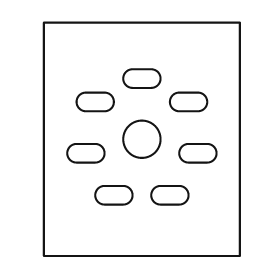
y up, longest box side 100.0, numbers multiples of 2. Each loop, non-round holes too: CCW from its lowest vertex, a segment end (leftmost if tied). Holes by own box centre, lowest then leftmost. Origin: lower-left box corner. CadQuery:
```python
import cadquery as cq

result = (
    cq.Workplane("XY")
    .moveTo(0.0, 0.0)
    .lineTo(84.0, 0.0)
    .lineTo(84.0, 100.0)
    .lineTo(0.0, 100.0)
    .close()
    .moveTo(26.0, 22.0)
    .lineTo(34.0, 22.0)
    .threePointArc((38.0, 26.0), (34.0, 30.0))
    .lineTo(26.0, 30.0)
    .threePointArc((22.0, 26.0), (26.0, 22.0))
    .close()
    .moveTo(50.0, 22.0)
    .lineTo(58.0, 22.0)
    .threePointArc((62.0, 26.0), (58.0, 30.0))
    .lineTo(50.0, 30.0)
    .threePointArc((46.0, 26.0), (50.0, 22.0))
    .close()
    .moveTo(14.0, 40.0)
    .lineTo(22.0, 40.0)
    .threePointArc((26.0, 44.0), (22.0, 48.0))
    .lineTo(14.0, 48.0)
    .threePointArc((10.0, 44.0), (14.0, 40.0))
    .close()
    .moveTo(62.0, 40.0)
    .lineTo(70.0, 40.0)
    .threePointArc((74.0, 44.0), (70.0, 48.0))
    .lineTo(62.0, 48.0)
    .threePointArc((58.0, 44.0), (62.0, 40.0))
    .close()
    .moveTo(42.0, 50.0)
    .circle(8.0)
    .moveTo(18.0, 62.0)
    .lineTo(26.0, 62.0)
    .threePointArc((30.0, 66.0), (26.0, 70.0))
    .lineTo(18.0, 70.0)
    .threePointArc((14.0, 66.0), (18.0, 62.0))
    .close()
    .moveTo(58.0, 62.0)
    .lineTo(66.0, 62.0)
    .threePointArc((70.0, 66.0), (66.0, 70.0))
    .lineTo(58.0, 70.0)
    .threePointArc((54.0, 66.0), (58.0, 62.0))
    .close()
    .moveTo(38.0, 72.0)
    .lineTo(46.0, 72.0)
    .threePointArc((50.0, 76.0), (46.0, 80.0))
    .lineTo(38.0, 80.0)
    .threePointArc((34.0, 76.0), (38.0, 72.0))
    .close()
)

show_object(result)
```